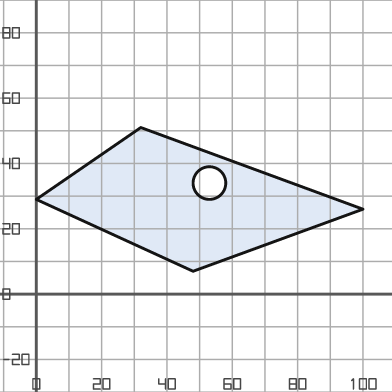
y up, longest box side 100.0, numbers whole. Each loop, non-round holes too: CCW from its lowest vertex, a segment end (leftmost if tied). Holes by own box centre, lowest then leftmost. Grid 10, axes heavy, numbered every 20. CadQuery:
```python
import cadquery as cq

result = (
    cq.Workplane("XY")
    .moveTo(48.0, 7.0)
    .lineTo(100.0, 26.0)
    .lineTo(32.0, 51.0)
    .lineTo(0.0, 29.0)
    .close()
    .moveTo(53.0, 34.0)
    .circle(5.0)
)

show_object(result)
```